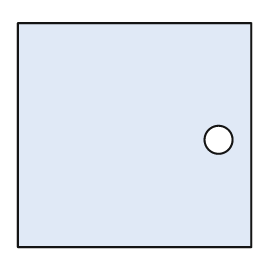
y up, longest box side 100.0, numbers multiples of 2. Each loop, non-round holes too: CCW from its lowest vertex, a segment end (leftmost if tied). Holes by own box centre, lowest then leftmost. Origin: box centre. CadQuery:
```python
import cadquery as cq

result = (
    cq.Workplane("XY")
    .moveTo(-50.0, -48.0)
    .lineTo(50.0, -48.0)
    .lineTo(50.0, 48.0)
    .lineTo(-50.0, 48.0)
    .close()
    .moveTo(36.0, -2.0)
    .circle(6.0)
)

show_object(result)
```